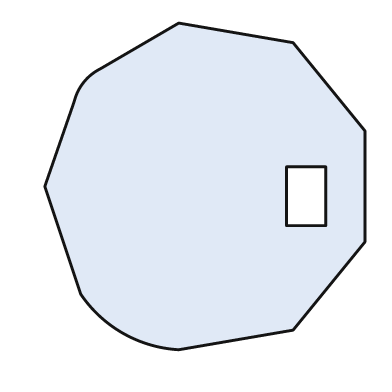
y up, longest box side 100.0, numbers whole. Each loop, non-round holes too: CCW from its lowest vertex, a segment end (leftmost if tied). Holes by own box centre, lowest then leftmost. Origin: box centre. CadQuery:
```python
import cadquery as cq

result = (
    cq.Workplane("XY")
    .moveTo(-8.0, -50.0)
    .lineTo(27.0, -44.0)
    .lineTo(49.0, -17.0)
    .lineTo(49.0, 17.0)
    .lineTo(27.0, 44.0)
    .lineTo(-8.0, 50.0)
    .lineTo(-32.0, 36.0)
    .threePointArc((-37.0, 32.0), (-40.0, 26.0))
    .lineTo(-49.0, 0.0)
    .lineTo(-38.0, -33.0)
    .threePointArc((-25.0, -45.0), (-8.0, -50.0))
    .close()
    .moveTo(25.0, -12.0)
    .lineTo(37.0, -12.0)
    .lineTo(37.0, 6.0)
    .lineTo(25.0, 6.0)
    .close()
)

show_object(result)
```